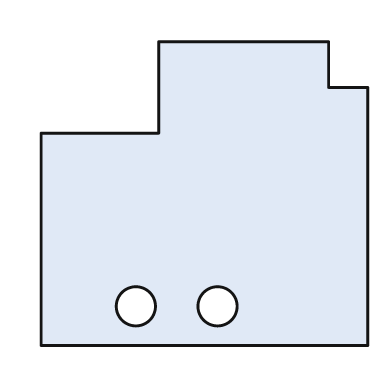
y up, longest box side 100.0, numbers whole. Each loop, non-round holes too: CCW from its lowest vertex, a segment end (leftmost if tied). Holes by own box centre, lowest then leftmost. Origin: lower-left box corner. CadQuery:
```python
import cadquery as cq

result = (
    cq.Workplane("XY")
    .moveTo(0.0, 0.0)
    .lineTo(100.0, 0.0)
    .lineTo(100.0, 79.0)
    .lineTo(88.0, 79.0)
    .lineTo(88.0, 93.0)
    .lineTo(36.0, 93.0)
    .lineTo(36.0, 65.0)
    .lineTo(0.0, 65.0)
    .close()
    .moveTo(29.0, 12.0)
    .circle(6.0)
    .moveTo(54.0, 12.0)
    .circle(6.0)
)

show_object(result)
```